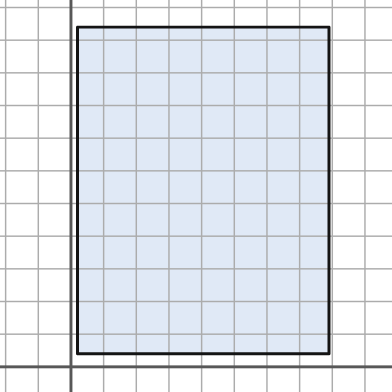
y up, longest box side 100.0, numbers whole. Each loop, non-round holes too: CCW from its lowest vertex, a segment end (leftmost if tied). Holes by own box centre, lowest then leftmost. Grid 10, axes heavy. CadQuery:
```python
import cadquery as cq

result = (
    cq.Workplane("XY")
    .moveTo(2.0, 4.0)
    .lineTo(79.0, 4.0)
    .lineTo(79.0, 104.0)
    .lineTo(2.0, 104.0)
    .close()
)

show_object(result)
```